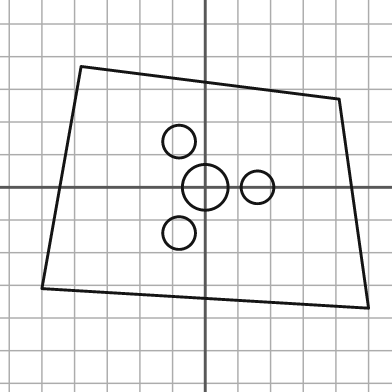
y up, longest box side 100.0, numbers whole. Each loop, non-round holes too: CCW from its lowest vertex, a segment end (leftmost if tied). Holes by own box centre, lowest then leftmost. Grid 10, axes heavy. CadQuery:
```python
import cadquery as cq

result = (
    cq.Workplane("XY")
    .moveTo(50.0, -37.0)
    .lineTo(41.0, 27.0)
    .lineTo(-38.0, 37.0)
    .lineTo(-50.0, -31.0)
    .close()
    .moveTo(-8.0, -14.0)
    .circle(5.0)
    .moveTo(0.0, 0.0)
    .circle(7.0)
    .moveTo(16.0, 0.0)
    .circle(5.0)
    .moveTo(-8.0, 14.0)
    .circle(5.0)
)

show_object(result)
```